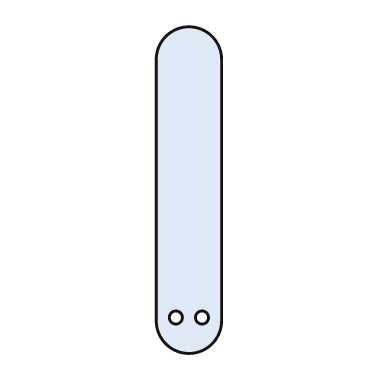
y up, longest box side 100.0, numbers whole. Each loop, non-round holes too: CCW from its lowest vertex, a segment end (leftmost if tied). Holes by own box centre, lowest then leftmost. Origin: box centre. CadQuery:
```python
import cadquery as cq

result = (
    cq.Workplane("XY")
    .moveTo(-10.0, -40.0)
    .threePointArc((0.0, -50.0), (10.0, -40.0))
    .lineTo(10.0, 40.0)
    .threePointArc((0.0, 50.0), (-10.0, 40.0))
    .close()
    .moveTo(-4.0, -39.0)
    .circle(2.0)
    .moveTo(4.0, -39.0)
    .circle(2.0)
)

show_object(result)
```